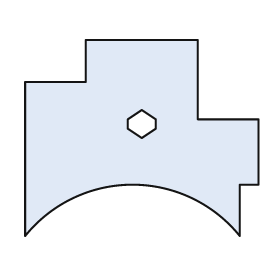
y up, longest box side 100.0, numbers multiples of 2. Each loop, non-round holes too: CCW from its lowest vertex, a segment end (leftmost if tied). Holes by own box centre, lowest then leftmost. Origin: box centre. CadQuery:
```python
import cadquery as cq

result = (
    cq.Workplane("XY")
    .moveTo(-50.0, -42.0)
    .threePointArc((-4.0, -20.0), (42.0, -42.0))
    .lineTo(42.0, -20.0)
    .lineTo(50.0, -20.0)
    .lineTo(50.0, 8.0)
    .lineTo(24.0, 8.0)
    .lineTo(24.0, 42.0)
    .lineTo(-24.0, 42.0)
    .lineTo(-24.0, 24.0)
    .lineTo(-50.0, 24.0)
    .close()
    .moveTo(0.0, 0.0)
    .lineTo(6.0, 4.0)
    .lineTo(6.0, 8.0)
    .lineTo(0.0, 12.0)
    .lineTo(-6.0, 8.0)
    .lineTo(-6.0, 4.0)
    .close()
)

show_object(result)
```